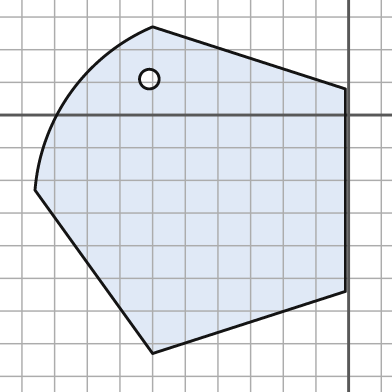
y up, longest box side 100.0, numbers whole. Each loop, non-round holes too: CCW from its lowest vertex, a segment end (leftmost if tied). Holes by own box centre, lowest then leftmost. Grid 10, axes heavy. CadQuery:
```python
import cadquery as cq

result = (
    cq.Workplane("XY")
    .moveTo(-60.0, -73.0)
    .lineTo(-1.0, -54.0)
    .lineTo(-1.0, 8.0)
    .lineTo(-60.0, 27.0)
    .threePointArc((-85.0, 7.0), (-96.0, -23.0))
    .close()
    .moveTo(-61.0, 11.0)
    .circle(3.0)
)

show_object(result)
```